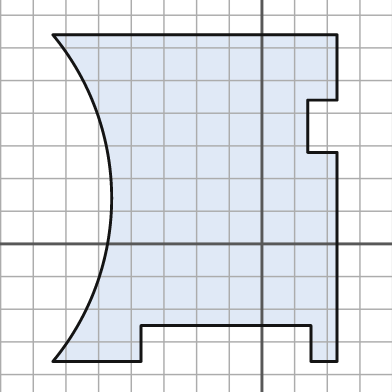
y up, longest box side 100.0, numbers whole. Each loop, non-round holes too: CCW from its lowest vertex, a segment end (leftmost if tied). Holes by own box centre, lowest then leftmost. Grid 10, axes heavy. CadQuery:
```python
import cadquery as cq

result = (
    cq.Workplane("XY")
    .moveTo(-64.0, -36.0)
    .lineTo(-37.0, -36.0)
    .lineTo(-37.0, -25.0)
    .lineTo(15.0, -25.0)
    .lineTo(15.0, -36.0)
    .lineTo(23.0, -36.0)
    .lineTo(23.0, 28.0)
    .lineTo(14.0, 28.0)
    .lineTo(14.0, 44.0)
    .lineTo(23.0, 44.0)
    .lineTo(23.0, 64.0)
    .lineTo(-64.0, 64.0)
    .threePointArc((-46.0, 14.0), (-64.0, -36.0))
    .close()
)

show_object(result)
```